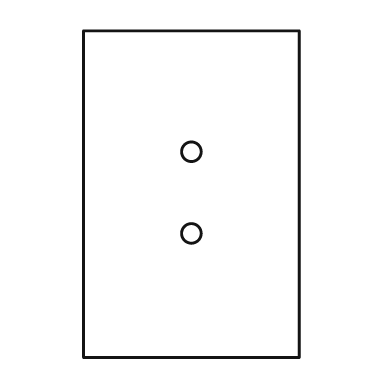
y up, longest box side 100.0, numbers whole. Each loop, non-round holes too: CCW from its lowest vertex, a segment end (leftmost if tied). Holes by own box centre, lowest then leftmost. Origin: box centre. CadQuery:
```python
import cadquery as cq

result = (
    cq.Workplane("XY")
    .moveTo(-33.0, -50.0)
    .lineTo(33.0, -50.0)
    .lineTo(33.0, 50.0)
    .lineTo(-33.0, 50.0)
    .close()
    .moveTo(0.0, -12.0)
    .circle(3.0)
    .moveTo(0.0, 13.0)
    .circle(3.0)
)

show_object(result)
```